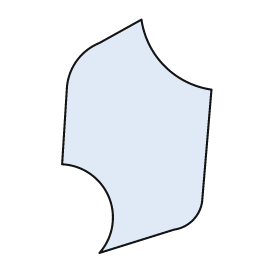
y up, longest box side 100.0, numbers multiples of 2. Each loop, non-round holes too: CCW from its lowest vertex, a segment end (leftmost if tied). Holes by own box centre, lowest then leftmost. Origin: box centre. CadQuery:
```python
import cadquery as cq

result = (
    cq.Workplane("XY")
    .moveTo(-16.0, -50.0)
    .lineTo(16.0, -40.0)
    .threePointArc((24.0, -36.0), (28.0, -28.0))
    .lineTo(32.0, 20.0)
    .threePointArc((12.0, 30.0), (2.0, 50.0))
    .lineTo(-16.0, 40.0)
    .threePointArc((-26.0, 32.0), (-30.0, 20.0))
    .lineTo(-32.0, -12.0)
    .threePointArc((-12.0, -26.0), (-16.0, -50.0))
    .close()
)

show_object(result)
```